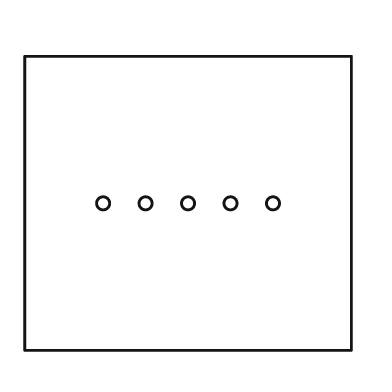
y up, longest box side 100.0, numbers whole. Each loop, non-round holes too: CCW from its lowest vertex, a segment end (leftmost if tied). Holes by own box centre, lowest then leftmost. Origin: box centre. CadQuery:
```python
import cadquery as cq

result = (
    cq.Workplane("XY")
    .moveTo(-50.0, -45.0)
    .lineTo(50.0, -45.0)
    .lineTo(50.0, 45.0)
    .lineTo(-50.0, 45.0)
    .close()
    .moveTo(-26.0, 0.0)
    .circle(2.0)
    .moveTo(-13.0, 0.0)
    .circle(2.0)
    .moveTo(0.0, 0.0)
    .circle(2.0)
    .moveTo(13.0, 0.0)
    .circle(2.0)
    .moveTo(26.0, 0.0)
    .circle(2.0)
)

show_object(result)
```